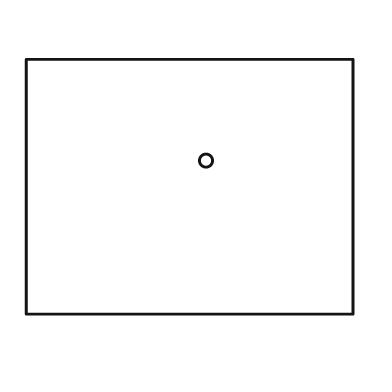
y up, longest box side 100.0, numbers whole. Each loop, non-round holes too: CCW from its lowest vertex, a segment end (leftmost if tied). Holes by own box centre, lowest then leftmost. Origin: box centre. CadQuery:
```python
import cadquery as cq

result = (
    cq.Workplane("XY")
    .moveTo(-50.0, -39.0)
    .lineTo(50.0, -39.0)
    .lineTo(50.0, 39.0)
    .lineTo(-50.0, 39.0)
    .close()
    .moveTo(5.0, 8.0)
    .circle(2.0)
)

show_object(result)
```